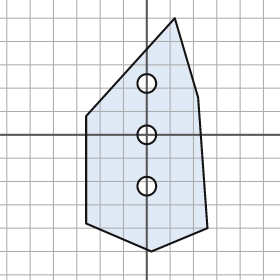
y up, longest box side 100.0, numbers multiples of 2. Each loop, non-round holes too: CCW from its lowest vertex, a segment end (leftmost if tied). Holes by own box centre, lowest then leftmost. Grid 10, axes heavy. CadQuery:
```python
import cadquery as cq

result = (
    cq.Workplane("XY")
    .moveTo(2.0, -50.0)
    .lineTo(26.0, -40.0)
    .lineTo(22.0, 16.0)
    .lineTo(12.0, 50.0)
    .lineTo(-26.0, 8.0)
    .lineTo(-26.0, -38.0)
    .close()
    .moveTo(0.0, -22.0)
    .circle(4.0)
    .moveTo(0.0, 0.0)
    .circle(4.0)
    .moveTo(0.0, 22.0)
    .circle(4.0)
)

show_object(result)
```